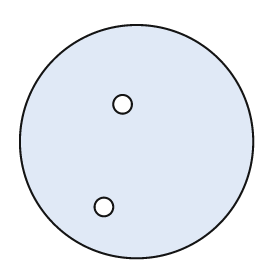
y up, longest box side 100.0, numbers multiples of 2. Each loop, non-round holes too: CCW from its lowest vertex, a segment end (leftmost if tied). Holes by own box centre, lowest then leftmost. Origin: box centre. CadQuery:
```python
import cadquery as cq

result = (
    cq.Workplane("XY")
    .moveTo(0.0, 0.0)
    .circle(50.0)
    .moveTo(-14.0, -28.0)
    .circle(4.0)
    .moveTo(-6.0, 16.0)
    .circle(4.0)
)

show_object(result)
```